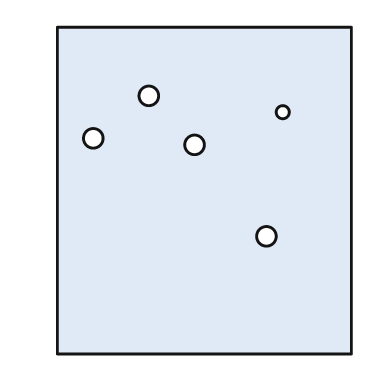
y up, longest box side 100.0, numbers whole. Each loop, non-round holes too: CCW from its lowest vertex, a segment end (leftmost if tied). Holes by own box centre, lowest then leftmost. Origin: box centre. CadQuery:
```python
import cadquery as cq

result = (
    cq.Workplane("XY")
    .moveTo(-45.0, -50.0)
    .lineTo(45.0, -50.0)
    .lineTo(45.0, 50.0)
    .lineTo(-45.0, 50.0)
    .close()
    .moveTo(19.0, -14.0)
    .circle(3.0)
    .moveTo(-3.0, 14.0)
    .circle(3.0)
    .moveTo(-34.0, 16.0)
    .circle(3.0)
    .moveTo(24.0, 24.0)
    .circle(2.0)
    .moveTo(-17.0, 29.0)
    .circle(3.0)
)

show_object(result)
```